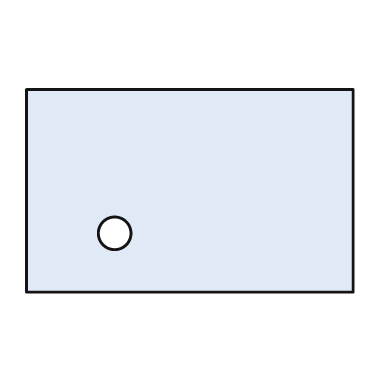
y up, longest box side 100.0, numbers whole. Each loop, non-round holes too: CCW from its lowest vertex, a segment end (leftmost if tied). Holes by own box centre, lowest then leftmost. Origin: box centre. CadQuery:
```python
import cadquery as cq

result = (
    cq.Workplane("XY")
    .moveTo(-50.0, -31.0)
    .lineTo(50.0, -31.0)
    .lineTo(50.0, 31.0)
    .lineTo(-50.0, 31.0)
    .close()
    .moveTo(-23.0, -13.0)
    .circle(5.0)
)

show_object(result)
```